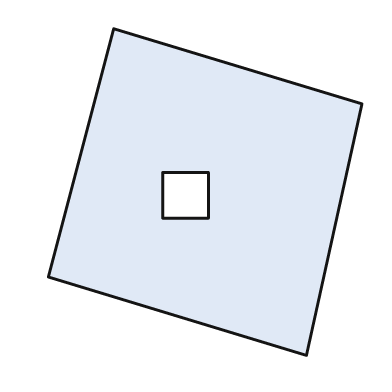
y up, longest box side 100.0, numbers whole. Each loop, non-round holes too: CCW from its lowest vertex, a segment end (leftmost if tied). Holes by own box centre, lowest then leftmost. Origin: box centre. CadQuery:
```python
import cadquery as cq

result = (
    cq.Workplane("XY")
    .moveTo(31.0, -50.0)
    .lineTo(48.0, 27.0)
    .lineTo(-28.0, 50.0)
    .lineTo(-48.0, -26.0)
    .close()
    .moveTo(-13.0, -8.0)
    .lineTo(1.0, -8.0)
    .lineTo(1.0, 6.0)
    .lineTo(-13.0, 6.0)
    .close()
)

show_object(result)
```